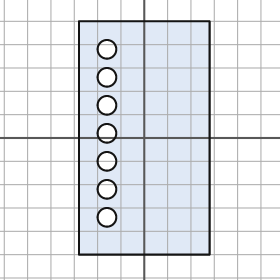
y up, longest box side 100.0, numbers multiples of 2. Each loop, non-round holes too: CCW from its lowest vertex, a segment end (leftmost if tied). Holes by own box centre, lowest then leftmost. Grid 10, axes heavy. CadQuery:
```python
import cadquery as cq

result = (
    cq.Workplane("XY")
    .moveTo(-28.0, -50.0)
    .lineTo(28.0, -50.0)
    .lineTo(28.0, 50.0)
    .lineTo(-28.0, 50.0)
    .close()
    .moveTo(-16.0, -34.0)
    .circle(4.0)
    .moveTo(-16.0, -22.0)
    .circle(4.0)
    .moveTo(-16.0, -10.0)
    .circle(4.0)
    .moveTo(-16.0, 2.0)
    .circle(4.0)
    .moveTo(-16.0, 14.0)
    .circle(4.0)
    .moveTo(-16.0, 26.0)
    .circle(4.0)
    .moveTo(-16.0, 38.0)
    .circle(4.0)
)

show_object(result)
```